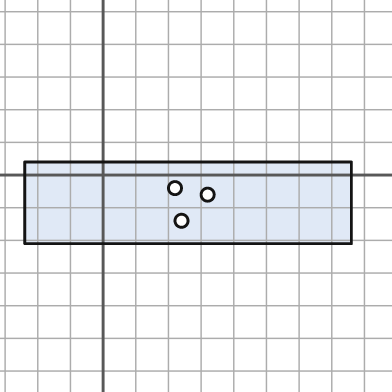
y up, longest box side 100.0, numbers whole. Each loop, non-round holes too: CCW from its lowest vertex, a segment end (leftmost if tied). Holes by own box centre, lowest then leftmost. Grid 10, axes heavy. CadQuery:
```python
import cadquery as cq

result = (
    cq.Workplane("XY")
    .moveTo(-24.0, -21.0)
    .lineTo(76.0, -21.0)
    .lineTo(76.0, 4.0)
    .lineTo(-24.0, 4.0)
    .close()
    .moveTo(24.0, -14.0)
    .circle(2.0)
    .moveTo(32.0, -6.0)
    .circle(2.0)
    .moveTo(22.0, -4.0)
    .circle(2.0)
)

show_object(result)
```